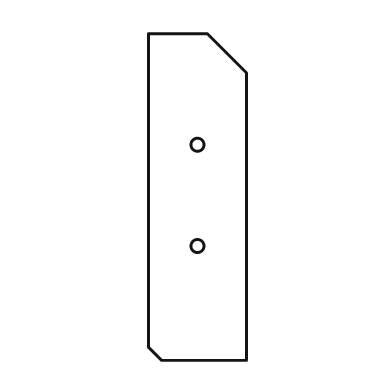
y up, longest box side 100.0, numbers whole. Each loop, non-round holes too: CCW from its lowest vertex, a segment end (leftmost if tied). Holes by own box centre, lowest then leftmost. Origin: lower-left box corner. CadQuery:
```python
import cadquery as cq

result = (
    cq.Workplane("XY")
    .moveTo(4.0, 0.0)
    .lineTo(30.0, 0.0)
    .lineTo(30.0, 88.0)
    .lineTo(18.0, 100.0)
    .lineTo(0.0, 100.0)
    .lineTo(0.0, 4.0)
    .close()
    .moveTo(15.0, 35.0)
    .circle(2.0)
    .moveTo(15.0, 66.0)
    .circle(2.0)
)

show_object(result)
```